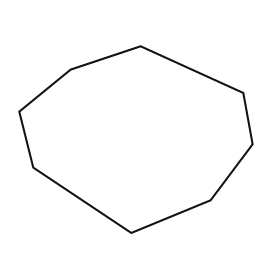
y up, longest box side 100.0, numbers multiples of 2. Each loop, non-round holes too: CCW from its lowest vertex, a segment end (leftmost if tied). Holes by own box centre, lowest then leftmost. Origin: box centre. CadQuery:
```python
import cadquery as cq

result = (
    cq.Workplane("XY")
    .moveTo(-2.0, -40.0)
    .lineTo(32.0, -26.0)
    .lineTo(50.0, -2.0)
    .lineTo(46.0, 20.0)
    .lineTo(2.0, 40.0)
    .lineTo(-28.0, 30.0)
    .lineTo(-50.0, 12.0)
    .lineTo(-44.0, -12.0)
    .close()
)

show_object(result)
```